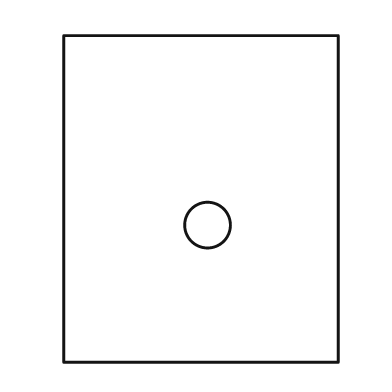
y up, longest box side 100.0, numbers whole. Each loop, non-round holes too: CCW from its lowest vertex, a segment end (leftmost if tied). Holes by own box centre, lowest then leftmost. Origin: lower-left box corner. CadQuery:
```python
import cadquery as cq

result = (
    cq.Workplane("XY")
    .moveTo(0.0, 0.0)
    .lineTo(84.0, 0.0)
    .lineTo(84.0, 100.0)
    .lineTo(0.0, 100.0)
    .close()
    .moveTo(44.0, 42.0)
    .circle(7.0)
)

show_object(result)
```